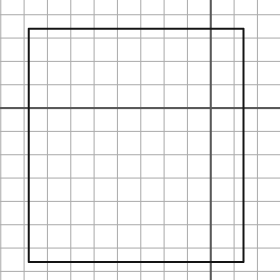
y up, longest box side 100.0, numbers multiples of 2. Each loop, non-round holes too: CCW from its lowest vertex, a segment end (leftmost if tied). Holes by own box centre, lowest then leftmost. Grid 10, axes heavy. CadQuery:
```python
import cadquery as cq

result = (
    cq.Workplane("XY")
    .moveTo(-78.0, -66.0)
    .lineTo(14.0, -66.0)
    .lineTo(14.0, 34.0)
    .lineTo(-78.0, 34.0)
    .close()
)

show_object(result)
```